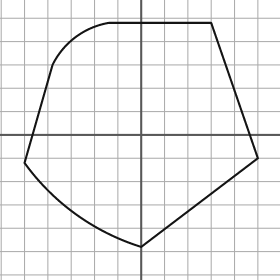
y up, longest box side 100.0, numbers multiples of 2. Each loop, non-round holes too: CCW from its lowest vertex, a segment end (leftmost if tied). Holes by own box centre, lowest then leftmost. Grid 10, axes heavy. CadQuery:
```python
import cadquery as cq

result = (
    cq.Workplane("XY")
    .moveTo(0.0, -48.0)
    .lineTo(50.0, -10.0)
    .lineTo(30.0, 48.0)
    .lineTo(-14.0, 48.0)
    .threePointArc((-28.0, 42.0), (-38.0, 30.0))
    .lineTo(-50.0, -12.0)
    .threePointArc((-28.0, -34.0), (0.0, -48.0))
    .close()
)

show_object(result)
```